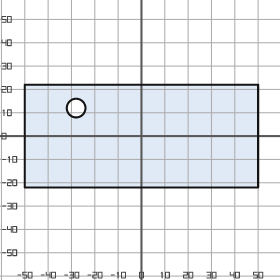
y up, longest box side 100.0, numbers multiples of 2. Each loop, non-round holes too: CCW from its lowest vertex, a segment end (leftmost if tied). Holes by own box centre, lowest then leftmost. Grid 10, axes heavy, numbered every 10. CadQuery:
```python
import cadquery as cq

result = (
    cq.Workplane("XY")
    .moveTo(-50.0, -22.0)
    .lineTo(50.0, -22.0)
    .lineTo(50.0, 22.0)
    .lineTo(-50.0, 22.0)
    .close()
    .moveTo(-28.0, 12.0)
    .circle(4.0)
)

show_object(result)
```